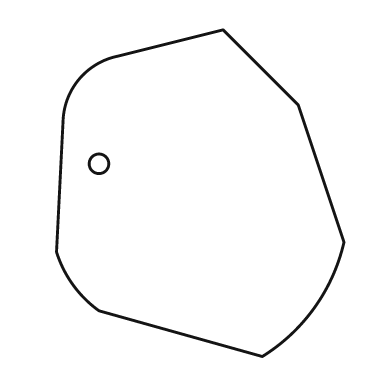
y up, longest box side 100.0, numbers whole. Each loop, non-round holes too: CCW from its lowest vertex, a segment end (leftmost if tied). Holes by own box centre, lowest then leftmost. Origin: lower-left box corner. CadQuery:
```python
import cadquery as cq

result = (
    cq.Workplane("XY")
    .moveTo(63.0, 0.0)
    .threePointArc((79.0, 15.0), (88.0, 35.0))
    .lineTo(74.0, 77.0)
    .lineTo(51.0, 100.0)
    .lineTo(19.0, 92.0)
    .threePointArc((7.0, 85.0), (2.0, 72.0))
    .lineTo(0.0, 32.0)
    .threePointArc((5.0, 22.0), (13.0, 14.0))
    .close()
    .moveTo(13.0, 59.0)
    .circle(3.0)
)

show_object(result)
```